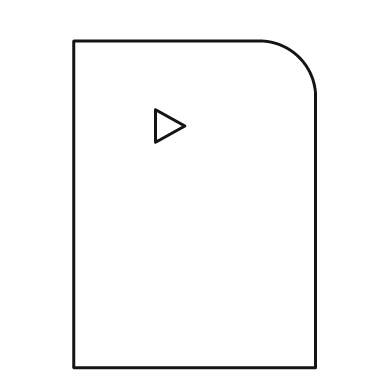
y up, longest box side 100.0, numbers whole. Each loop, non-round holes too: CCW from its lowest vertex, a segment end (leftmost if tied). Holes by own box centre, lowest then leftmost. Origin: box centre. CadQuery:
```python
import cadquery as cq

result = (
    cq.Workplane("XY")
    .moveTo(-37.0, -50.0)
    .lineTo(37.0, -50.0)
    .lineTo(37.0, 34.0)
    .threePointArc((32.0, 45.0), (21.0, 50.0))
    .lineTo(-37.0, 50.0)
    .close()
    .moveTo(-12.0, 19.0)
    .lineTo(-3.0, 24.0)
    .lineTo(-12.0, 29.0)
    .close()
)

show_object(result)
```